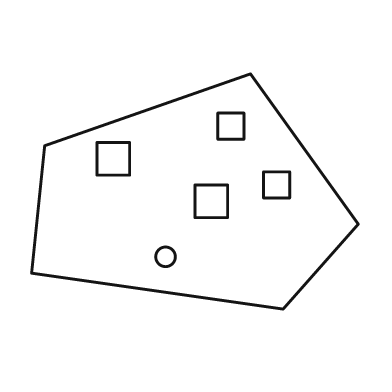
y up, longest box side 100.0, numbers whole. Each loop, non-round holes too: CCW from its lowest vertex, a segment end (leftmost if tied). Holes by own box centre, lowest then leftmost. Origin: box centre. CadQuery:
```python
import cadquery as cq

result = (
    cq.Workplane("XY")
    .moveTo(27.0, -36.0)
    .lineTo(50.0, -10.0)
    .lineTo(17.0, 36.0)
    .lineTo(-46.0, 14.0)
    .lineTo(-50.0, -25.0)
    .close()
    .moveTo(-9.0, -20.0)
    .circle(3.0)
    .moveTo(0.0, -8.0)
    .lineTo(10.0, -8.0)
    .lineTo(10.0, 2.0)
    .lineTo(0.0, 2.0)
    .close()
    .moveTo(21.0, -2.0)
    .lineTo(29.0, -2.0)
    .lineTo(29.0, 6.0)
    .lineTo(21.0, 6.0)
    .close()
    .moveTo(-30.0, 5.0)
    .lineTo(-20.0, 5.0)
    .lineTo(-20.0, 15.0)
    .lineTo(-30.0, 15.0)
    .close()
    .moveTo(7.0, 16.0)
    .lineTo(15.0, 16.0)
    .lineTo(15.0, 24.0)
    .lineTo(7.0, 24.0)
    .close()
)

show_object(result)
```